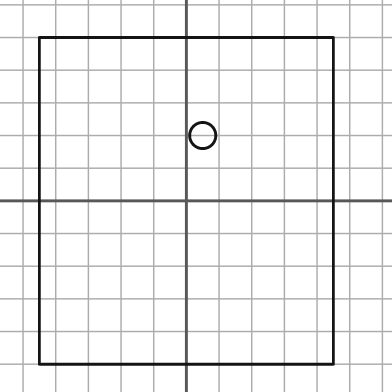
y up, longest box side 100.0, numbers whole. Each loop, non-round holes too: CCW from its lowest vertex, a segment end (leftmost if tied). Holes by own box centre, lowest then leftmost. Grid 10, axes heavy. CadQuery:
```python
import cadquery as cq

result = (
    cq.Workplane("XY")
    .moveTo(-45.0, -50.0)
    .lineTo(45.0, -50.0)
    .lineTo(45.0, 50.0)
    .lineTo(-45.0, 50.0)
    .close()
    .moveTo(5.0, 20.0)
    .circle(4.0)
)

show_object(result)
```